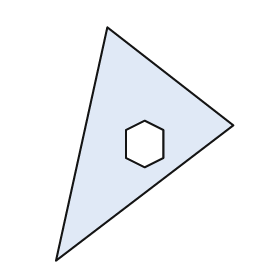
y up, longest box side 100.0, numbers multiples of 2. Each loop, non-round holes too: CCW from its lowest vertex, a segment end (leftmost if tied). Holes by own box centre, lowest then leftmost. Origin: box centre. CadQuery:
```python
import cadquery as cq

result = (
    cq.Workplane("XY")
    .moveTo(-38.0, -50.0)
    .lineTo(38.0, 8.0)
    .lineTo(-16.0, 50.0)
    .close()
    .moveTo(0.0, -10.0)
    .lineTo(8.0, -6.0)
    .lineTo(8.0, 6.0)
    .lineTo(0.0, 10.0)
    .lineTo(-8.0, 6.0)
    .lineTo(-8.0, -6.0)
    .close()
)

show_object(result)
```